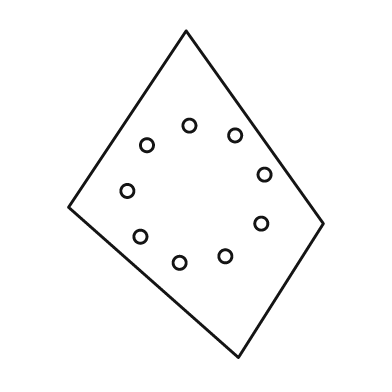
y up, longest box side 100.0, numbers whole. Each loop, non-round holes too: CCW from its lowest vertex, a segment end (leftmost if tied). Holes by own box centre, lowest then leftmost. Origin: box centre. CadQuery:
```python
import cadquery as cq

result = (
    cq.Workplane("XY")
    .moveTo(13.0, -50.0)
    .lineTo(39.0, -9.0)
    .lineTo(-3.0, 50.0)
    .lineTo(-39.0, -4.0)
    .close()
    .moveTo(-5.0, -21.0)
    .circle(2.0)
    .moveTo(9.0, -19.0)
    .circle(2.0)
    .moveTo(-17.0, -13.0)
    .circle(2.0)
    .moveTo(20.0, -9.0)
    .circle(2.0)
    .moveTo(-21.0, 1.0)
    .circle(2.0)
    .moveTo(21.0, 6.0)
    .circle(2.0)
    .moveTo(-15.0, 15.0)
    .circle(2.0)
    .moveTo(12.0, 18.0)
    .circle(2.0)
    .moveTo(-2.0, 21.0)
    .circle(2.0)
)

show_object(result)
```